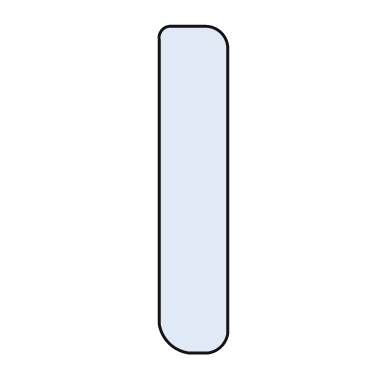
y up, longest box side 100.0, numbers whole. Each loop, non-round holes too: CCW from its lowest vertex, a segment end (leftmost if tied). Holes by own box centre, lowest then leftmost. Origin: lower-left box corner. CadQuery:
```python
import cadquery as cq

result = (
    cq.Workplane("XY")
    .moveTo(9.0, 0.0)
    .lineTo(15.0, 0.0)
    .threePointArc((19.0, 2.0), (21.0, 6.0))
    .lineTo(21.0, 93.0)
    .threePointArc((19.0, 98.0), (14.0, 100.0))
    .lineTo(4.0, 100.0)
    .threePointArc((1.0, 99.0), (0.0, 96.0))
    .lineTo(0.0, 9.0)
    .threePointArc((3.0, 3.0), (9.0, 0.0))
    .close()
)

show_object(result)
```